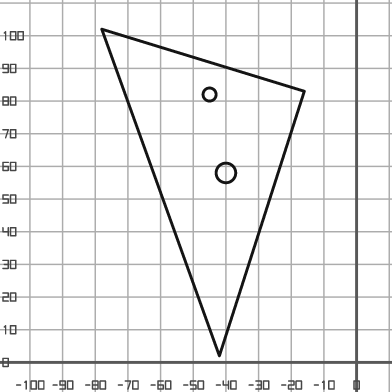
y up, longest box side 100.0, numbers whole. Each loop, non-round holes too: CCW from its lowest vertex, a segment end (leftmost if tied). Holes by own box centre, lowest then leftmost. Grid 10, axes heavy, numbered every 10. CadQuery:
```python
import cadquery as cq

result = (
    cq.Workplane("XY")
    .moveTo(-42.0, 2.0)
    .lineTo(-16.0, 83.0)
    .lineTo(-78.0, 102.0)
    .close()
    .moveTo(-40.0, 58.0)
    .circle(3.0)
    .moveTo(-45.0, 82.0)
    .circle(2.0)
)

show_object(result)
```